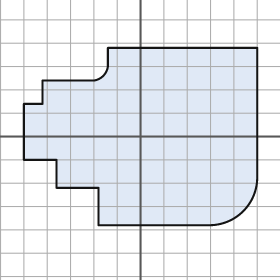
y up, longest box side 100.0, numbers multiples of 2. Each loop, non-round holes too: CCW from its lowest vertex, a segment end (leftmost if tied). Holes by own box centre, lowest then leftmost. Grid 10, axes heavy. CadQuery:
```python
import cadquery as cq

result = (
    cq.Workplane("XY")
    .moveTo(-18.0, -38.0)
    .lineTo(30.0, -38.0)
    .threePointArc((44.0, -32.0), (50.0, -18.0))
    .lineTo(50.0, 38.0)
    .lineTo(-14.0, 38.0)
    .lineTo(-14.0, 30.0)
    .threePointArc((-16.0, 26.0), (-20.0, 24.0))
    .lineTo(-42.0, 24.0)
    .lineTo(-42.0, 14.0)
    .lineTo(-50.0, 14.0)
    .lineTo(-50.0, -10.0)
    .lineTo(-36.0, -10.0)
    .lineTo(-36.0, -22.0)
    .lineTo(-18.0, -22.0)
    .close()
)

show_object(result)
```